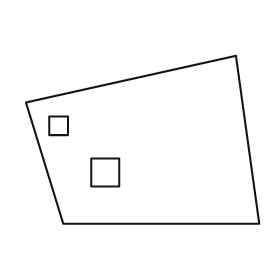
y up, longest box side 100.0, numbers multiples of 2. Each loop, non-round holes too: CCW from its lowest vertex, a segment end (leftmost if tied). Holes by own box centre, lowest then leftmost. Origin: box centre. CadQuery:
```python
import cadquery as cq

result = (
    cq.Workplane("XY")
    .moveTo(-34.0, -36.0)
    .lineTo(50.0, -36.0)
    .lineTo(40.0, 36.0)
    .lineTo(-50.0, 16.0)
    .close()
    .moveTo(-22.0, -20.0)
    .lineTo(-10.0, -20.0)
    .lineTo(-10.0, -8.0)
    .lineTo(-22.0, -8.0)
    .close()
    .moveTo(-40.0, 2.0)
    .lineTo(-32.0, 2.0)
    .lineTo(-32.0, 10.0)
    .lineTo(-40.0, 10.0)
    .close()
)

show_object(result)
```